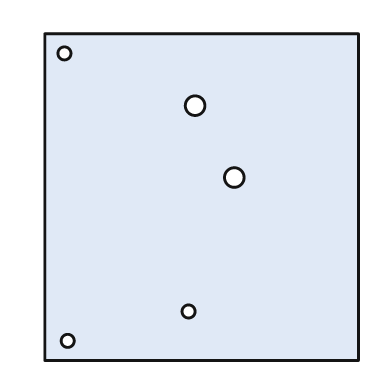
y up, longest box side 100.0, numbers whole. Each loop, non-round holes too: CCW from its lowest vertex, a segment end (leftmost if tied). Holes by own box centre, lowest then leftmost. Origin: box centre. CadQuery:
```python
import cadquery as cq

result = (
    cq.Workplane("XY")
    .moveTo(-48.0, -50.0)
    .lineTo(48.0, -50.0)
    .lineTo(48.0, 50.0)
    .lineTo(-48.0, 50.0)
    .close()
    .moveTo(-41.0, -44.0)
    .circle(2.0)
    .moveTo(-4.0, -35.0)
    .circle(2.0)
    .moveTo(10.0, 6.0)
    .circle(3.0)
    .moveTo(-2.0, 28.0)
    .circle(3.0)
    .moveTo(-42.0, 44.0)
    .circle(2.0)
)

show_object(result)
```